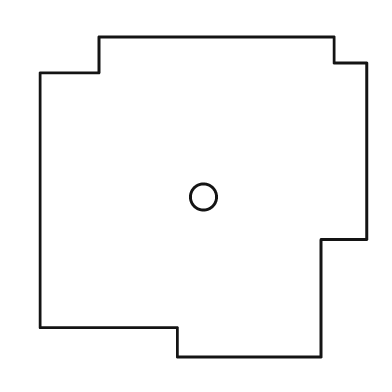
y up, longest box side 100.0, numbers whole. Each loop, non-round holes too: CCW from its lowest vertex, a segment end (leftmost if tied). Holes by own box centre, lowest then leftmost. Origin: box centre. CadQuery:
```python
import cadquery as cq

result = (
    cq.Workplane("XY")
    .moveTo(-8.0, -49.0)
    .lineTo(36.0, -49.0)
    .lineTo(36.0, -13.0)
    .lineTo(50.0, -13.0)
    .lineTo(50.0, 41.0)
    .lineTo(40.0, 41.0)
    .lineTo(40.0, 49.0)
    .lineTo(-32.0, 49.0)
    .lineTo(-32.0, 38.0)
    .lineTo(-50.0, 38.0)
    .lineTo(-50.0, -40.0)
    .lineTo(-8.0, -40.0)
    .close()
    .moveTo(0.0, 0.0)
    .circle(4.0)
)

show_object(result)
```